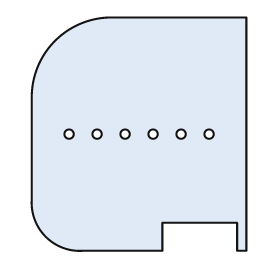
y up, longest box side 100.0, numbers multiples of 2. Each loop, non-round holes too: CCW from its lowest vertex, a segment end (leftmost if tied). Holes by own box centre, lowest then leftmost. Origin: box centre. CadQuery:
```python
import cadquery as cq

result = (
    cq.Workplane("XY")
    .moveTo(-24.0, -50.0)
    .lineTo(10.0, -50.0)
    .lineTo(10.0, -38.0)
    .lineTo(42.0, -38.0)
    .lineTo(42.0, -50.0)
    .lineTo(46.0, -50.0)
    .lineTo(46.0, 50.0)
    .lineTo(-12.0, 50.0)
    .threePointArc((-36.0, 40.0), (-46.0, 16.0))
    .lineTo(-46.0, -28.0)
    .threePointArc((-40.0, -44.0), (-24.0, -50.0))
    .close()
    .moveTo(-30.0, 0.0)
    .circle(2.0)
    .moveTo(-18.0, 0.0)
    .circle(2.0)
    .moveTo(-6.0, 0.0)
    .circle(2.0)
    .moveTo(6.0, 0.0)
    .circle(2.0)
    .moveTo(18.0, 0.0)
    .circle(2.0)
    .moveTo(30.0, 0.0)
    .circle(2.0)
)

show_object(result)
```